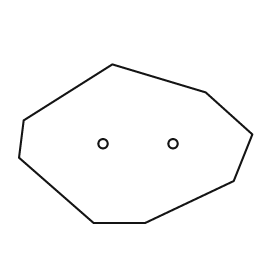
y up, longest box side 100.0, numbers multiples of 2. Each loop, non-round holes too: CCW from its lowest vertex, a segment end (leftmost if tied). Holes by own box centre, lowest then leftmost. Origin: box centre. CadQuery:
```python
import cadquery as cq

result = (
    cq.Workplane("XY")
    .moveTo(-18.0, -34.0)
    .lineTo(4.0, -34.0)
    .lineTo(42.0, -16.0)
    .lineTo(50.0, 4.0)
    .lineTo(30.0, 22.0)
    .lineTo(-10.0, 34.0)
    .lineTo(-48.0, 10.0)
    .lineTo(-50.0, -6.0)
    .close()
    .moveTo(-14.0, 0.0)
    .circle(2.0)
    .moveTo(16.0, 0.0)
    .circle(2.0)
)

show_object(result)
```